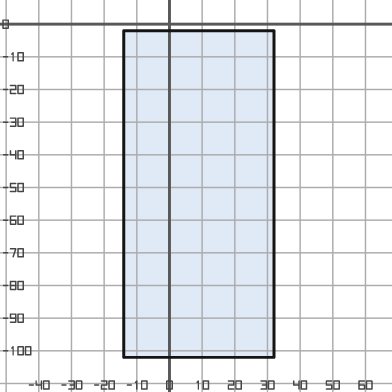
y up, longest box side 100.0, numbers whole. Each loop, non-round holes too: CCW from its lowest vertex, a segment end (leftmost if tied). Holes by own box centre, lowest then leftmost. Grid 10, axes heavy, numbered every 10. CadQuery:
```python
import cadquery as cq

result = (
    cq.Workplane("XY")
    .moveTo(-14.0, -102.0)
    .lineTo(32.0, -102.0)
    .lineTo(32.0, -2.0)
    .lineTo(-14.0, -2.0)
    .close()
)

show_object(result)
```